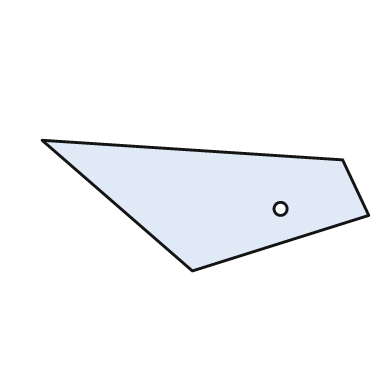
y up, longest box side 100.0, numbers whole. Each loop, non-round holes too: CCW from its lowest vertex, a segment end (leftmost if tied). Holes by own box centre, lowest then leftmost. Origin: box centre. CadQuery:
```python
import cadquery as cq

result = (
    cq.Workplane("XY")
    .moveTo(-4.0, -20.0)
    .lineTo(50.0, -3.0)
    .lineTo(42.0, 14.0)
    .lineTo(-50.0, 20.0)
    .close()
    .moveTo(23.0, -1.0)
    .circle(2.0)
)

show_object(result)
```